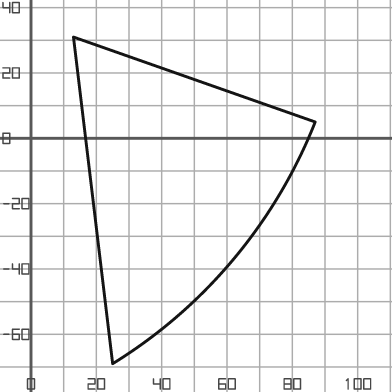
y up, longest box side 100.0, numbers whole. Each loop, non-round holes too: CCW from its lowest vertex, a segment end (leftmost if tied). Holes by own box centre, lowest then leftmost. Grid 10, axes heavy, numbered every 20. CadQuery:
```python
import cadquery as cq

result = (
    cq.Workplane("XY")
    .moveTo(25.0, -69.0)
    .threePointArc((62.0, -37.0), (87.0, 5.0))
    .lineTo(13.0, 31.0)
    .close()
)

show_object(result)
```